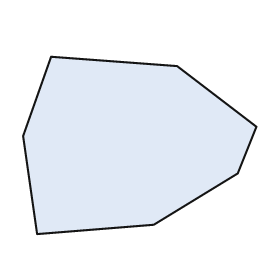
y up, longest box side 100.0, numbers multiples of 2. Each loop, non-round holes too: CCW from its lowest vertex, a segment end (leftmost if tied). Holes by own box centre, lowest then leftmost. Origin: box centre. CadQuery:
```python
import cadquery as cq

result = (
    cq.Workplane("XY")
    .moveTo(-44.0, -38.0)
    .lineTo(6.0, -34.0)
    .lineTo(42.0, -12.0)
    .lineTo(50.0, 8.0)
    .lineTo(16.0, 34.0)
    .lineTo(-38.0, 38.0)
    .lineTo(-50.0, 4.0)
    .close()
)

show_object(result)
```